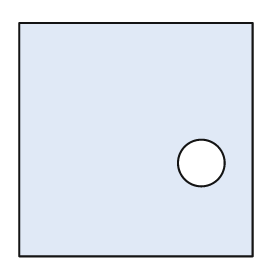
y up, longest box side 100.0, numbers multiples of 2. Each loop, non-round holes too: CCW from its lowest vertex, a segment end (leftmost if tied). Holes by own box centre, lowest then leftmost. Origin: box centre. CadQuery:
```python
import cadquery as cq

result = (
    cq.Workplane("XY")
    .moveTo(-50.0, -50.0)
    .lineTo(50.0, -50.0)
    .lineTo(50.0, 50.0)
    .lineTo(-50.0, 50.0)
    .close()
    .moveTo(28.0, -10.0)
    .circle(10.0)
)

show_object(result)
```